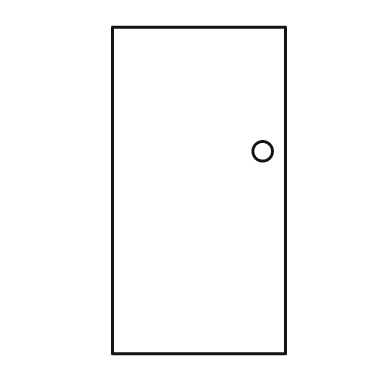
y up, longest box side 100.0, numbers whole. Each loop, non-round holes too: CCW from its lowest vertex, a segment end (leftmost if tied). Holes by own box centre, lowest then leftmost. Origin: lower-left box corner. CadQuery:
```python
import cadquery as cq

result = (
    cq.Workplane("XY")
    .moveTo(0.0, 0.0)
    .lineTo(53.0, 0.0)
    .lineTo(53.0, 100.0)
    .lineTo(0.0, 100.0)
    .close()
    .moveTo(46.0, 62.0)
    .circle(3.0)
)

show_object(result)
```